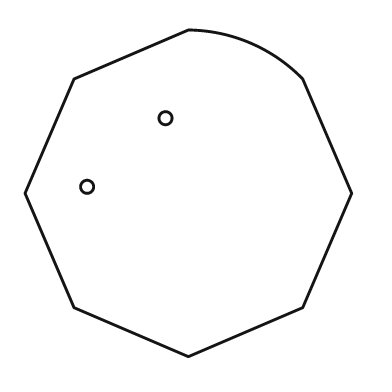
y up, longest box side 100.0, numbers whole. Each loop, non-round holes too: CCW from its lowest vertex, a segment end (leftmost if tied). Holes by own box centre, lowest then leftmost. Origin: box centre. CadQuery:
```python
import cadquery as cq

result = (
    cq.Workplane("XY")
    .moveTo(0.0, -50.0)
    .lineTo(35.0, -35.0)
    .lineTo(50.0, 0.0)
    .lineTo(35.0, 35.0)
    .threePointArc((19.0, 46.0), (0.0, 50.0))
    .lineTo(-35.0, 35.0)
    .lineTo(-50.0, 0.0)
    .lineTo(-35.0, -35.0)
    .close()
    .moveTo(-31.0, 2.0)
    .circle(2.0)
    .moveTo(-7.0, 23.0)
    .circle(2.0)
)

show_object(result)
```